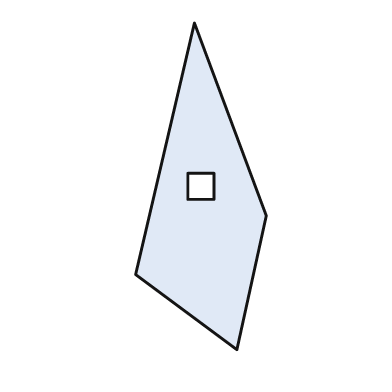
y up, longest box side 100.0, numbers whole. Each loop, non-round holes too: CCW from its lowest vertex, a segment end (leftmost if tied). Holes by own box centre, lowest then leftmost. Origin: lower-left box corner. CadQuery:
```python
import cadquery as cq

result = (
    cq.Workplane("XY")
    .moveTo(31.0, 0.0)
    .lineTo(40.0, 41.0)
    .lineTo(18.0, 100.0)
    .lineTo(0.0, 23.0)
    .close()
    .moveTo(16.0, 46.0)
    .lineTo(24.0, 46.0)
    .lineTo(24.0, 54.0)
    .lineTo(16.0, 54.0)
    .close()
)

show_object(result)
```